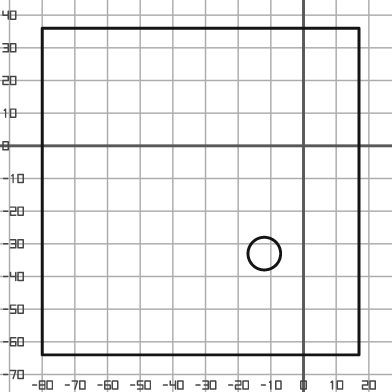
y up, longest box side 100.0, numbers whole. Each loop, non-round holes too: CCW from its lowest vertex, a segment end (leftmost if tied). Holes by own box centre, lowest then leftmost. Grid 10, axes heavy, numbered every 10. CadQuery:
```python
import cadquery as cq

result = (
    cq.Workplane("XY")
    .moveTo(-80.0, -64.0)
    .lineTo(17.0, -64.0)
    .lineTo(17.0, 36.0)
    .lineTo(-80.0, 36.0)
    .close()
    .moveTo(-12.0, -33.0)
    .circle(5.0)
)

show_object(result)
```